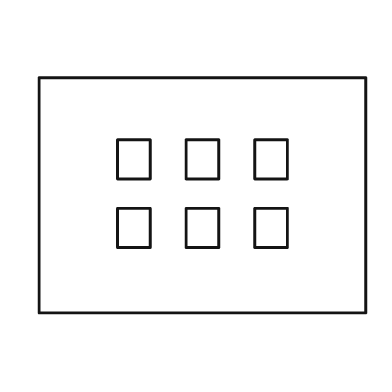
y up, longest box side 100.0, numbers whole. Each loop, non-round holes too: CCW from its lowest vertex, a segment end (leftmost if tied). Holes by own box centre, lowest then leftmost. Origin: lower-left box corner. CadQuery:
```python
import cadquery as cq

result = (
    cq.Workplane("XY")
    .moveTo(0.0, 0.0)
    .lineTo(100.0, 0.0)
    .lineTo(100.0, 72.0)
    .lineTo(0.0, 72.0)
    .close()
    .moveTo(24.0, 20.0)
    .lineTo(34.0, 20.0)
    .lineTo(34.0, 32.0)
    .lineTo(24.0, 32.0)
    .close()
    .moveTo(45.0, 20.0)
    .lineTo(55.0, 20.0)
    .lineTo(55.0, 32.0)
    .lineTo(45.0, 32.0)
    .close()
    .moveTo(66.0, 20.0)
    .lineTo(76.0, 20.0)
    .lineTo(76.0, 32.0)
    .lineTo(66.0, 32.0)
    .close()
    .moveTo(24.0, 41.0)
    .lineTo(34.0, 41.0)
    .lineTo(34.0, 53.0)
    .lineTo(24.0, 53.0)
    .close()
    .moveTo(45.0, 41.0)
    .lineTo(55.0, 41.0)
    .lineTo(55.0, 53.0)
    .lineTo(45.0, 53.0)
    .close()
    .moveTo(66.0, 41.0)
    .lineTo(76.0, 41.0)
    .lineTo(76.0, 53.0)
    .lineTo(66.0, 53.0)
    .close()
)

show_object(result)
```